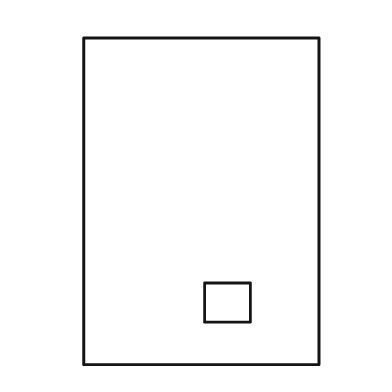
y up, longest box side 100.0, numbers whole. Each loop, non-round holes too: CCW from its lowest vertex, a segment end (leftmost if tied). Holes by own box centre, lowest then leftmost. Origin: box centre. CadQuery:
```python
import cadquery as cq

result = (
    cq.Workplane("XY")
    .moveTo(-36.0, -50.0)
    .lineTo(36.0, -50.0)
    .lineTo(36.0, 50.0)
    .lineTo(-36.0, 50.0)
    .close()
    .moveTo(1.0, -37.0)
    .lineTo(15.0, -37.0)
    .lineTo(15.0, -25.0)
    .lineTo(1.0, -25.0)
    .close()
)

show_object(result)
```